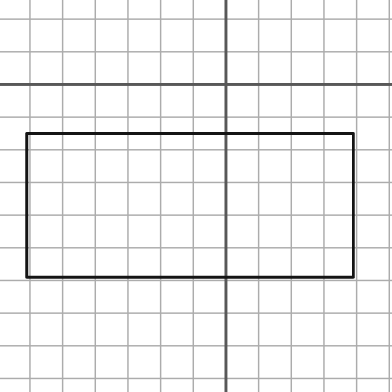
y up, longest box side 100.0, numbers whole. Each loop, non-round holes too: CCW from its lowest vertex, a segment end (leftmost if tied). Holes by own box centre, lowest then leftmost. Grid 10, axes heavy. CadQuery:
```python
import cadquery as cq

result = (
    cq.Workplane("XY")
    .moveTo(-61.0, -59.0)
    .lineTo(39.0, -59.0)
    .lineTo(39.0, -15.0)
    .lineTo(-61.0, -15.0)
    .close()
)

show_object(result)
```